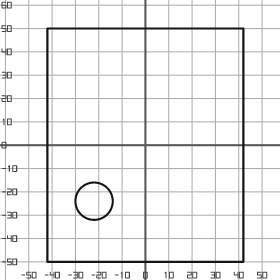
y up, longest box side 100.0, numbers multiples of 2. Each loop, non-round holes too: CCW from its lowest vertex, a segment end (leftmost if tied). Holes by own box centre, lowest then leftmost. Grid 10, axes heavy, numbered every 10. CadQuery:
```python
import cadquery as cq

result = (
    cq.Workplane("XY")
    .moveTo(-42.0, -50.0)
    .lineTo(42.0, -50.0)
    .lineTo(42.0, 50.0)
    .lineTo(-42.0, 50.0)
    .close()
    .moveTo(-22.0, -24.0)
    .circle(8.0)
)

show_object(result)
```